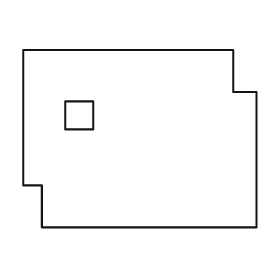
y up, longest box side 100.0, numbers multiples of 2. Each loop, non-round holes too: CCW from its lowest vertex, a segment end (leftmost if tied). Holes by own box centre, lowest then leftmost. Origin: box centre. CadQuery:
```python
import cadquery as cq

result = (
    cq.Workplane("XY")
    .moveTo(-42.0, -38.0)
    .lineTo(50.0, -38.0)
    .lineTo(50.0, 20.0)
    .lineTo(40.0, 20.0)
    .lineTo(40.0, 38.0)
    .lineTo(-50.0, 38.0)
    .lineTo(-50.0, -20.0)
    .lineTo(-42.0, -20.0)
    .close()
    .moveTo(-32.0, 4.0)
    .lineTo(-20.0, 4.0)
    .lineTo(-20.0, 16.0)
    .lineTo(-32.0, 16.0)
    .close()
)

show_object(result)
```